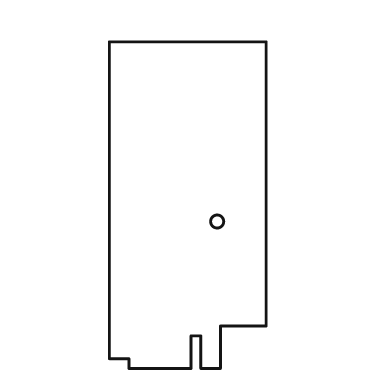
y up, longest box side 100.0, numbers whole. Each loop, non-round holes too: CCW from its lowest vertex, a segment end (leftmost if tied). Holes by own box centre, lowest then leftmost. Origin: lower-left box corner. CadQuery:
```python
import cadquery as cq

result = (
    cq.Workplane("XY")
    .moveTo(6.0, 0.0)
    .lineTo(25.0, 0.0)
    .lineTo(25.0, 10.0)
    .lineTo(28.0, 10.0)
    .lineTo(28.0, 0.0)
    .lineTo(34.0, 0.0)
    .lineTo(34.0, 13.0)
    .lineTo(48.0, 13.0)
    .lineTo(48.0, 100.0)
    .lineTo(0.0, 100.0)
    .lineTo(0.0, 3.0)
    .lineTo(6.0, 3.0)
    .close()
    .moveTo(33.0, 45.0)
    .circle(2.0)
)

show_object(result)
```